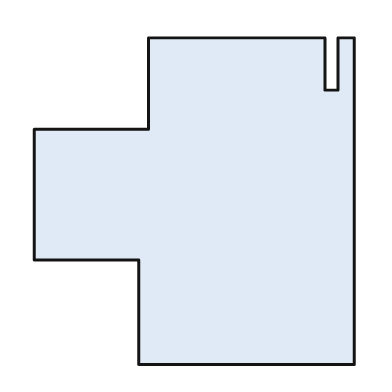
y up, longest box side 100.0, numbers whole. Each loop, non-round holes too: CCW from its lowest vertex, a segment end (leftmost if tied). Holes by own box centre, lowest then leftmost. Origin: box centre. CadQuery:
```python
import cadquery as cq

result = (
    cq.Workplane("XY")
    .moveTo(-17.0, -50.0)
    .lineTo(49.0, -50.0)
    .lineTo(49.0, 50.0)
    .lineTo(44.0, 50.0)
    .lineTo(44.0, 34.0)
    .lineTo(40.0, 34.0)
    .lineTo(40.0, 50.0)
    .lineTo(-14.0, 50.0)
    .lineTo(-14.0, 22.0)
    .lineTo(-49.0, 22.0)
    .lineTo(-49.0, -18.0)
    .lineTo(-17.0, -18.0)
    .close()
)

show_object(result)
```